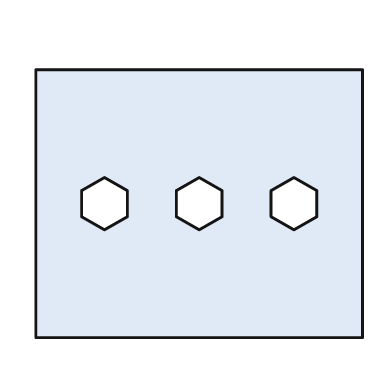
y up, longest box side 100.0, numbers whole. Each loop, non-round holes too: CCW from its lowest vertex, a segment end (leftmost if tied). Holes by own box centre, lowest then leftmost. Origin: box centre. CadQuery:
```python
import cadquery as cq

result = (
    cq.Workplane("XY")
    .moveTo(-50.0, -41.0)
    .lineTo(50.0, -41.0)
    .lineTo(50.0, 41.0)
    .lineTo(-50.0, 41.0)
    .close()
    .moveTo(-29.0, -8.0)
    .lineTo(-22.0, -4.0)
    .lineTo(-22.0, 4.0)
    .lineTo(-29.0, 8.0)
    .lineTo(-36.0, 4.0)
    .lineTo(-36.0, -4.0)
    .close()
    .moveTo(0.0, -8.0)
    .lineTo(7.0, -4.0)
    .lineTo(7.0, 4.0)
    .lineTo(0.0, 8.0)
    .lineTo(-7.0, 4.0)
    .lineTo(-7.0, -4.0)
    .close()
    .moveTo(29.0, -8.0)
    .lineTo(36.0, -4.0)
    .lineTo(36.0, 4.0)
    .lineTo(29.0, 8.0)
    .lineTo(22.0, 4.0)
    .lineTo(22.0, -4.0)
    .close()
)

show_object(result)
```